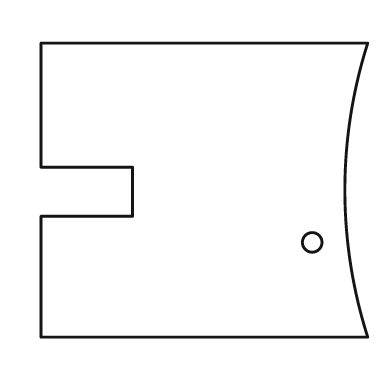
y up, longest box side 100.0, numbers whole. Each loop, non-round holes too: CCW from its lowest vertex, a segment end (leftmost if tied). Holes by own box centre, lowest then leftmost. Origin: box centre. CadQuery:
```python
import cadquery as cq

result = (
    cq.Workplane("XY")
    .moveTo(-50.0, -45.0)
    .lineTo(50.0, -45.0)
    .threePointArc((43.0, 0.0), (50.0, 45.0))
    .lineTo(-50.0, 45.0)
    .lineTo(-50.0, 7.0)
    .lineTo(-22.0, 7.0)
    .lineTo(-22.0, -8.0)
    .lineTo(-50.0, -8.0)
    .close()
    .moveTo(33.0, -16.0)
    .circle(3.0)
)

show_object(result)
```